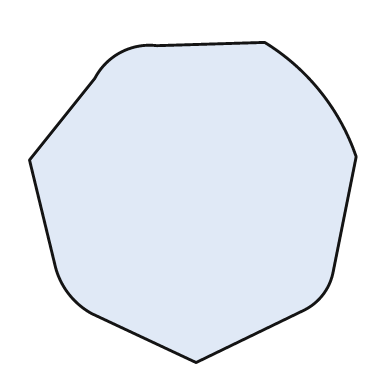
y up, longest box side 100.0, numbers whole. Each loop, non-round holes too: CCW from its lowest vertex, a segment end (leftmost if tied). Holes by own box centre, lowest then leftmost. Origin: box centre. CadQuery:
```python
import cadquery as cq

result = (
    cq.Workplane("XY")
    .moveTo(1.0, -49.0)
    .lineTo(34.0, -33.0)
    .threePointArc((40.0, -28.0), (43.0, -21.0))
    .lineTo(50.0, 14.0)
    .threePointArc((39.0, 34.0), (22.0, 49.0))
    .lineTo(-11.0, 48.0)
    .threePointArc((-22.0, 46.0), (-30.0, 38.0))
    .lineTo(-50.0, 13.0)
    .lineTo(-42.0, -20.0)
    .threePointArc((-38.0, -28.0), (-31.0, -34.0))
    .close()
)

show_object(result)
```